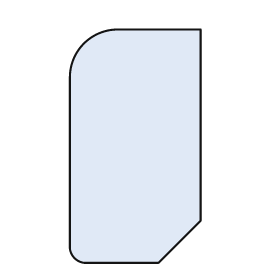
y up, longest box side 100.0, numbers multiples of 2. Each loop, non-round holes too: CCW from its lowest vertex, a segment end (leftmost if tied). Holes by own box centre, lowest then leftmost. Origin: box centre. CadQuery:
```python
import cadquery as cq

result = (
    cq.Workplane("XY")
    .moveTo(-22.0, -50.0)
    .lineTo(10.0, -50.0)
    .lineTo(28.0, -32.0)
    .lineTo(28.0, 50.0)
    .lineTo(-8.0, 50.0)
    .threePointArc((-22.0, 44.0), (-28.0, 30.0))
    .lineTo(-28.0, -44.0)
    .threePointArc((-26.0, -48.0), (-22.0, -50.0))
    .close()
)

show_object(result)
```